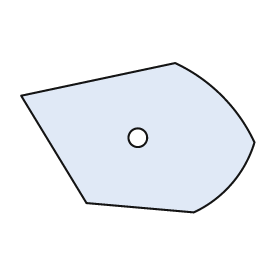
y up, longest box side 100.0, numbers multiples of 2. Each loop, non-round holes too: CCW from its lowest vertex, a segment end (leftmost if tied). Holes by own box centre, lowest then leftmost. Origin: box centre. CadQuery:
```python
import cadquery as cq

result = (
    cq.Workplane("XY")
    .moveTo(24.0, -32.0)
    .threePointArc((40.0, -20.0), (50.0, -2.0))
    .threePointArc((36.0, 18.0), (16.0, 32.0))
    .lineTo(-50.0, 18.0)
    .lineTo(-22.0, -28.0)
    .close()
    .moveTo(0.0, 0.0)
    .circle(4.0)
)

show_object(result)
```